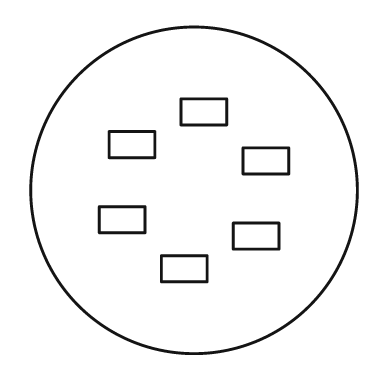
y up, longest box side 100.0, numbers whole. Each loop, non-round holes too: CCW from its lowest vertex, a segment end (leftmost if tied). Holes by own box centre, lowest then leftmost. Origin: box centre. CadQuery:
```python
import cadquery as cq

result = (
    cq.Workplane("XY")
    .moveTo(0.0, 0.0)
    .circle(50.0)
    .moveTo(-10.0, -28.0)
    .lineTo(4.0, -28.0)
    .lineTo(4.0, -20.0)
    .lineTo(-10.0, -20.0)
    .close()
    .moveTo(12.0, -18.0)
    .lineTo(26.0, -18.0)
    .lineTo(26.0, -10.0)
    .lineTo(12.0, -10.0)
    .close()
    .moveTo(-29.0, -13.0)
    .lineTo(-15.0, -13.0)
    .lineTo(-15.0, -5.0)
    .lineTo(-29.0, -5.0)
    .close()
    .moveTo(15.0, 5.0)
    .lineTo(29.0, 5.0)
    .lineTo(29.0, 13.0)
    .lineTo(15.0, 13.0)
    .close()
    .moveTo(-26.0, 10.0)
    .lineTo(-12.0, 10.0)
    .lineTo(-12.0, 18.0)
    .lineTo(-26.0, 18.0)
    .close()
    .moveTo(-4.0, 20.0)
    .lineTo(10.0, 20.0)
    .lineTo(10.0, 28.0)
    .lineTo(-4.0, 28.0)
    .close()
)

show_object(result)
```